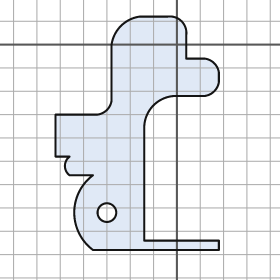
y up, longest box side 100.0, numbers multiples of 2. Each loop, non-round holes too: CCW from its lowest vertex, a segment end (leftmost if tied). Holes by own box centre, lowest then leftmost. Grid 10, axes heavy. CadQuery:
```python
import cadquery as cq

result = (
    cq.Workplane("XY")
    .moveTo(-36.0, -88.0)
    .lineTo(18.0, -88.0)
    .lineTo(18.0, -84.0)
    .lineTo(-14.0, -84.0)
    .lineTo(-14.0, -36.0)
    .threePointArc((-10.0, -26.0), (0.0, -22.0))
    .lineTo(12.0, -22.0)
    .threePointArc((16.0, -20.0), (18.0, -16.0))
    .lineTo(18.0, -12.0)
    .threePointArc((16.0, -8.0), (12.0, -6.0))
    .lineTo(4.0, -6.0)
    .lineTo(4.0, 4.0)
    .threePointArc((2.0, 10.0), (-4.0, 12.0))
    .lineTo(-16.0, 12.0)
    .threePointArc((-24.0, 8.0), (-28.0, 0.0))
    .lineTo(-28.0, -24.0)
    .threePointArc((-30.0, -28.0), (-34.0, -30.0))
    .lineTo(-52.0, -30.0)
    .lineTo(-52.0, -48.0)
    .lineTo(-46.0, -48.0)
    .threePointArc((-48.0, -52.0), (-46.0, -56.0))
    .lineTo(-36.0, -56.0)
    .threePointArc((-44.0, -72.0), (-36.0, -88.0))
    .close()
    .moveTo(-30.0, -72.0)
    .circle(4.0)
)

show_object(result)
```